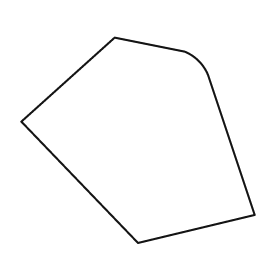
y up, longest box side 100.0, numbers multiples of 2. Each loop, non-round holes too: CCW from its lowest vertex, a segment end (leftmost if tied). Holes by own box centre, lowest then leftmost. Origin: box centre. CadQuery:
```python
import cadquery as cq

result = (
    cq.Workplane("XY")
    .moveTo(0.0, -44.0)
    .lineTo(50.0, -32.0)
    .lineTo(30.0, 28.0)
    .threePointArc((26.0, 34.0), (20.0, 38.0))
    .lineTo(-10.0, 44.0)
    .lineTo(-50.0, 8.0)
    .close()
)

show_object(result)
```